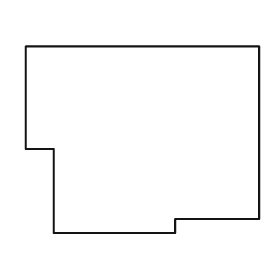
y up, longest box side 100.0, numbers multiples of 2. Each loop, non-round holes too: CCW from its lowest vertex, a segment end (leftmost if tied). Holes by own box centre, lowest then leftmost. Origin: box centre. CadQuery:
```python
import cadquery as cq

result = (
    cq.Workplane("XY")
    .moveTo(-38.0, -40.0)
    .lineTo(14.0, -40.0)
    .lineTo(14.0, -34.0)
    .lineTo(50.0, -34.0)
    .lineTo(50.0, 40.0)
    .lineTo(-50.0, 40.0)
    .lineTo(-50.0, -4.0)
    .lineTo(-38.0, -4.0)
    .close()
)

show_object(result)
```